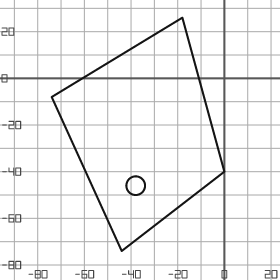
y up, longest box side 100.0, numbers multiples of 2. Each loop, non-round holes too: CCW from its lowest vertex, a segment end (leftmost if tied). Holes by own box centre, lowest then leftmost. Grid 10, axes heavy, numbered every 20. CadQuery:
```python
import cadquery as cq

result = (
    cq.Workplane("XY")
    .moveTo(-44.0, -74.0)
    .lineTo(0.0, -40.0)
    .lineTo(-18.0, 26.0)
    .lineTo(-74.0, -8.0)
    .close()
    .moveTo(-38.0, -46.0)
    .circle(4.0)
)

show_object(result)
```